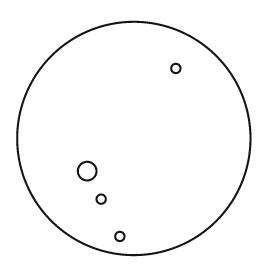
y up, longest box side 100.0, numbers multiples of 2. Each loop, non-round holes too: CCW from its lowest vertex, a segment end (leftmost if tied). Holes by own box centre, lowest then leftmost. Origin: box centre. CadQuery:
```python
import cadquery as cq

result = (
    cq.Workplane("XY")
    .moveTo(0.0, 0.0)
    .circle(50.0)
    .moveTo(-6.0, -42.0)
    .circle(2.0)
    .moveTo(-14.0, -26.0)
    .circle(2.0)
    .moveTo(-20.0, -14.0)
    .circle(4.0)
    .moveTo(18.0, 30.0)
    .circle(2.0)
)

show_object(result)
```